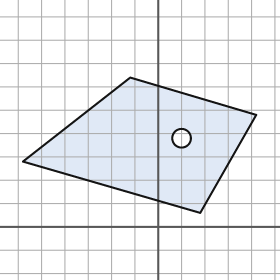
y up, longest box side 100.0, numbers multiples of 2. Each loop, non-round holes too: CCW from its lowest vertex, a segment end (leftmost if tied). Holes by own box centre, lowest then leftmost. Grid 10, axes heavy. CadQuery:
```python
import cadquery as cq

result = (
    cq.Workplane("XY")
    .moveTo(18.0, 6.0)
    .lineTo(42.0, 48.0)
    .lineTo(-12.0, 64.0)
    .lineTo(-58.0, 28.0)
    .close()
    .moveTo(10.0, 38.0)
    .circle(4.0)
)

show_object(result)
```